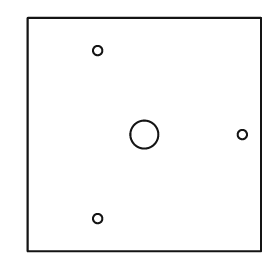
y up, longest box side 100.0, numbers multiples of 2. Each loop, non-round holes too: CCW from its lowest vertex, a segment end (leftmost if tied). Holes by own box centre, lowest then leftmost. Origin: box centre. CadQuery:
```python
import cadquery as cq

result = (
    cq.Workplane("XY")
    .moveTo(-50.0, -50.0)
    .lineTo(50.0, -50.0)
    .lineTo(50.0, 50.0)
    .lineTo(-50.0, 50.0)
    .close()
    .moveTo(-20.0, -36.0)
    .circle(2.0)
    .moveTo(0.0, 0.0)
    .circle(6.0)
    .moveTo(42.0, 0.0)
    .circle(2.0)
    .moveTo(-20.0, 36.0)
    .circle(2.0)
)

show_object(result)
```